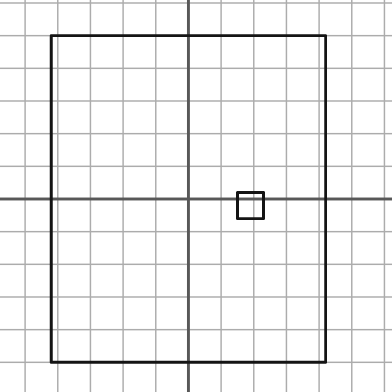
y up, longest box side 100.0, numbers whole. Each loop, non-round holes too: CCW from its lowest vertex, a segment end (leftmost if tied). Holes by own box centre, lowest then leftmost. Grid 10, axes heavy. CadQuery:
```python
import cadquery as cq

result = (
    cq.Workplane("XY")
    .moveTo(-42.0, -50.0)
    .lineTo(42.0, -50.0)
    .lineTo(42.0, 50.0)
    .lineTo(-42.0, 50.0)
    .close()
    .moveTo(15.0, -6.0)
    .lineTo(23.0, -6.0)
    .lineTo(23.0, 2.0)
    .lineTo(15.0, 2.0)
    .close()
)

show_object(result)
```